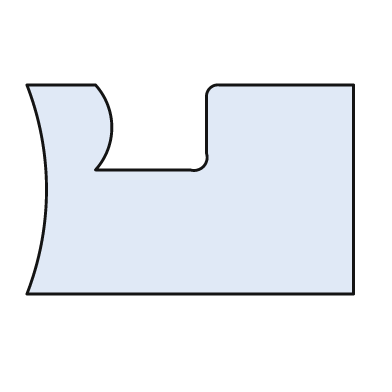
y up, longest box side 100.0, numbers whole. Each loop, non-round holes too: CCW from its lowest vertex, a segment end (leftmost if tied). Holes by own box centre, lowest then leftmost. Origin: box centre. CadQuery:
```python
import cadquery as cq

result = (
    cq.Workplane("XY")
    .moveTo(-50.0, -32.0)
    .lineTo(50.0, -32.0)
    .lineTo(50.0, 32.0)
    .lineTo(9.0, 32.0)
    .threePointArc((6.0, 31.0), (5.0, 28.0))
    .lineTo(5.0, 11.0)
    .threePointArc((4.0, 7.0), (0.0, 6.0))
    .lineTo(-29.0, 6.0)
    .threePointArc((-24.0, 19.0), (-29.0, 32.0))
    .lineTo(-50.0, 32.0)
    .threePointArc((-44.0, 0.0), (-50.0, -32.0))
    .close()
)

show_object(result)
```